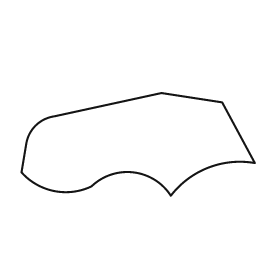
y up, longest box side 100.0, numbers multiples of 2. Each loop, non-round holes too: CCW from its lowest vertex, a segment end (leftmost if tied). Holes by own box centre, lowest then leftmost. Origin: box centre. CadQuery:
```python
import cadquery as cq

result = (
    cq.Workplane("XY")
    .moveTo(14.0, -22.0)
    .threePointArc((30.0, -10.0), (50.0, -8.0))
    .lineTo(36.0, 18.0)
    .lineTo(10.0, 22.0)
    .lineTo(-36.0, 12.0)
    .threePointArc((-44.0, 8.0), (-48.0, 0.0))
    .lineTo(-50.0, -12.0)
    .threePointArc((-36.0, -20.0), (-20.0, -18.0))
    .threePointArc((-2.0, -12.0), (14.0, -22.0))
    .close()
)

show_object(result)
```